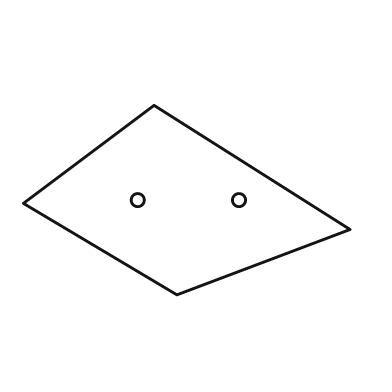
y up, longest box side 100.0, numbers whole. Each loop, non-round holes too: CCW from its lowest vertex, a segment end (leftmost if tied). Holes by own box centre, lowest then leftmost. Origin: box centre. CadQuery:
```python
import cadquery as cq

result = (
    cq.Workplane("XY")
    .moveTo(-3.0, -29.0)
    .lineTo(50.0, -9.0)
    .lineTo(-10.0, 29.0)
    .lineTo(-50.0, -1.0)
    .close()
    .moveTo(-15.0, 0.0)
    .circle(2.0)
    .moveTo(16.0, 0.0)
    .circle(2.0)
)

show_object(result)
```